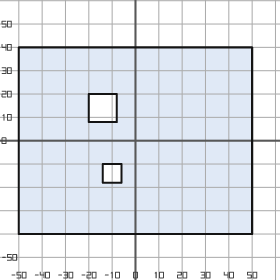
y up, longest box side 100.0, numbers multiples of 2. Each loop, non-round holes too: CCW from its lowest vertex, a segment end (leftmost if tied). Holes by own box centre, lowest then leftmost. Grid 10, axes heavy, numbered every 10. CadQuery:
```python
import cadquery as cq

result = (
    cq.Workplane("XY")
    .moveTo(-50.0, -40.0)
    .lineTo(50.0, -40.0)
    .lineTo(50.0, 40.0)
    .lineTo(-50.0, 40.0)
    .close()
    .moveTo(-14.0, -18.0)
    .lineTo(-6.0, -18.0)
    .lineTo(-6.0, -10.0)
    .lineTo(-14.0, -10.0)
    .close()
    .moveTo(-20.0, 8.0)
    .lineTo(-8.0, 8.0)
    .lineTo(-8.0, 20.0)
    .lineTo(-20.0, 20.0)
    .close()
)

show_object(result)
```